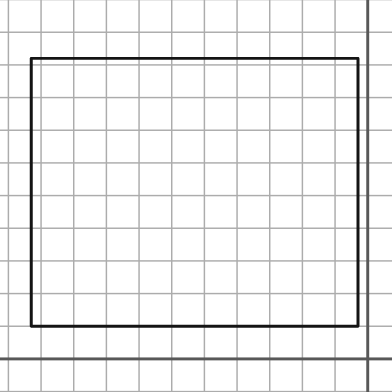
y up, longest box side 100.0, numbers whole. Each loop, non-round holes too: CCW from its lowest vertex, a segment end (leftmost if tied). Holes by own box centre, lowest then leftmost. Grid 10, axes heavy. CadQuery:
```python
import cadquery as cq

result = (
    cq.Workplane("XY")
    .moveTo(-103.0, 10.0)
    .lineTo(-3.0, 10.0)
    .lineTo(-3.0, 92.0)
    .lineTo(-103.0, 92.0)
    .close()
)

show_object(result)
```